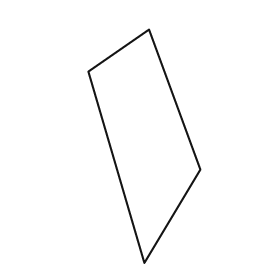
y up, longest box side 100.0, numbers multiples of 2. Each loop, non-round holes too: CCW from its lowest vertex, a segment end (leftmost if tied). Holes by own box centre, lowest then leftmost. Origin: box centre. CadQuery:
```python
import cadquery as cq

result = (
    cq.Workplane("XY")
    .moveTo(0.0, -50.0)
    .lineTo(24.0, -10.0)
    .lineTo(2.0, 50.0)
    .lineTo(-24.0, 32.0)
    .close()
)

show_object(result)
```